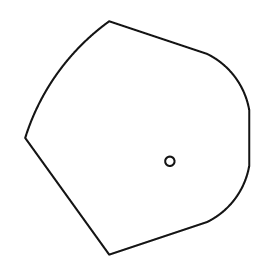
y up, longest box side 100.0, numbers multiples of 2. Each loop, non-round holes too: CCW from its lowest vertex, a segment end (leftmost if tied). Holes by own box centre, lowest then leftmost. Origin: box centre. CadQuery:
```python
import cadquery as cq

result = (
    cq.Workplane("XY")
    .moveTo(-12.0, -50.0)
    .lineTo(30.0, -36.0)
    .threePointArc((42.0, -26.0), (48.0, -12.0))
    .lineTo(48.0, 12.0)
    .threePointArc((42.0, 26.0), (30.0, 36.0))
    .lineTo(-12.0, 50.0)
    .threePointArc((-34.0, 28.0), (-48.0, 0.0))
    .close()
    .moveTo(14.0, -10.0)
    .circle(2.0)
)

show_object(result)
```